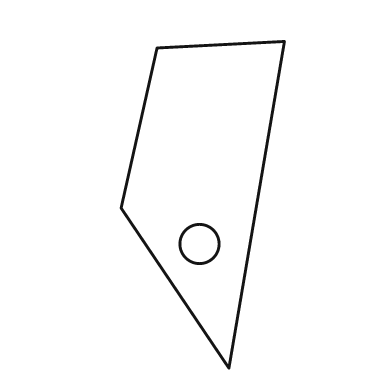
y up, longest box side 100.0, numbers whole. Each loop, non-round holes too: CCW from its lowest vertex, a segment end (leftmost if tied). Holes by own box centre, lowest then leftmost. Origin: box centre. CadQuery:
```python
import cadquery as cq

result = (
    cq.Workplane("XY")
    .moveTo(8.0, -50.0)
    .lineTo(25.0, 50.0)
    .lineTo(-14.0, 48.0)
    .lineTo(-25.0, -1.0)
    .close()
    .moveTo(-1.0, -12.0)
    .circle(6.0)
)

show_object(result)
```